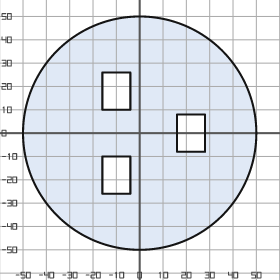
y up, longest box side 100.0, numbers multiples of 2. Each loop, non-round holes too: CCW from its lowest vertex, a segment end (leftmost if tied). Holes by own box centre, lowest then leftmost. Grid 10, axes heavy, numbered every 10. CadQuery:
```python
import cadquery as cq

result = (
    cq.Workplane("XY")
    .moveTo(0.0, 0.0)
    .circle(50.0)
    .moveTo(-16.0, -26.0)
    .lineTo(-4.0, -26.0)
    .lineTo(-4.0, -10.0)
    .lineTo(-16.0, -10.0)
    .close()
    .moveTo(16.0, -8.0)
    .lineTo(28.0, -8.0)
    .lineTo(28.0, 8.0)
    .lineTo(16.0, 8.0)
    .close()
    .moveTo(-16.0, 10.0)
    .lineTo(-4.0, 10.0)
    .lineTo(-4.0, 26.0)
    .lineTo(-16.0, 26.0)
    .close()
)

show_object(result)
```